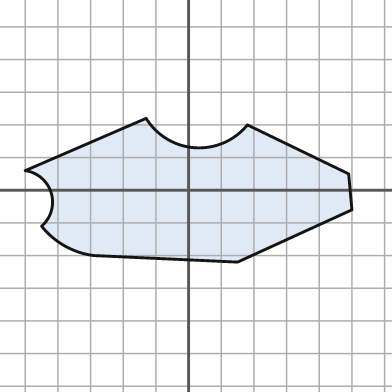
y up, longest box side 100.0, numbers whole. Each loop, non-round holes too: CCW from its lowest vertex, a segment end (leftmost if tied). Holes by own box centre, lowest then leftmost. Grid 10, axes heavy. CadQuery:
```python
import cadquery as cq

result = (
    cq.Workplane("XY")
    .moveTo(15.0, -22.0)
    .lineTo(50.0, -6.0)
    .lineTo(49.0, 5.0)
    .lineTo(18.0, 20.0)
    .threePointArc((2.0, 13.0), (-13.0, 22.0))
    .lineTo(-50.0, 6.0)
    .threePointArc((-42.0, -1.0), (-45.0, -11.0))
    .threePointArc((-38.0, -17.0), (-29.0, -20.0))
    .close()
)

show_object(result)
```